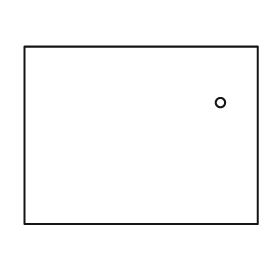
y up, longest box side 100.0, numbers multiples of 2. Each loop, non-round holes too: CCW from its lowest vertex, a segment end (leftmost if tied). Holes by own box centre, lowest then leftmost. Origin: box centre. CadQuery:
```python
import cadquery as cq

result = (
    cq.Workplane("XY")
    .moveTo(-50.0, -38.0)
    .lineTo(50.0, -38.0)
    .lineTo(50.0, 38.0)
    .lineTo(-50.0, 38.0)
    .close()
    .moveTo(34.0, 14.0)
    .circle(2.0)
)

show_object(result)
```